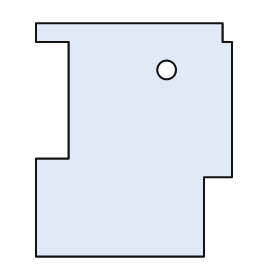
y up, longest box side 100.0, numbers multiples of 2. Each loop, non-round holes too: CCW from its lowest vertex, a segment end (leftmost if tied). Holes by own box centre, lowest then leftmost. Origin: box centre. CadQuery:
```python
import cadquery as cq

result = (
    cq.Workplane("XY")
    .moveTo(-42.0, -50.0)
    .lineTo(30.0, -50.0)
    .lineTo(30.0, -16.0)
    .lineTo(42.0, -16.0)
    .lineTo(42.0, 42.0)
    .lineTo(38.0, 42.0)
    .lineTo(38.0, 50.0)
    .lineTo(-42.0, 50.0)
    .lineTo(-42.0, 42.0)
    .lineTo(-28.0, 42.0)
    .lineTo(-28.0, -8.0)
    .lineTo(-42.0, -8.0)
    .close()
    .moveTo(14.0, 30.0)
    .circle(4.0)
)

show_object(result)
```